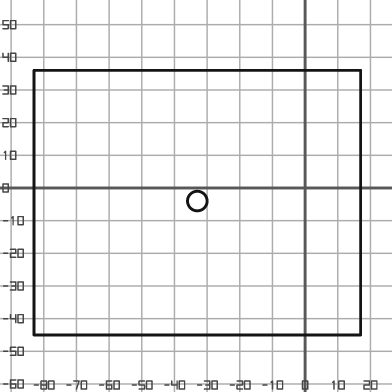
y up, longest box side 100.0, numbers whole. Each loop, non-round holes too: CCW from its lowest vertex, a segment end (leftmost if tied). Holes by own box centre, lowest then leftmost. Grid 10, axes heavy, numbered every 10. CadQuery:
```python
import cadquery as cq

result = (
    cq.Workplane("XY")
    .moveTo(-83.0, -45.0)
    .lineTo(17.0, -45.0)
    .lineTo(17.0, 36.0)
    .lineTo(-83.0, 36.0)
    .close()
    .moveTo(-33.0, -4.0)
    .circle(3.0)
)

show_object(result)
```